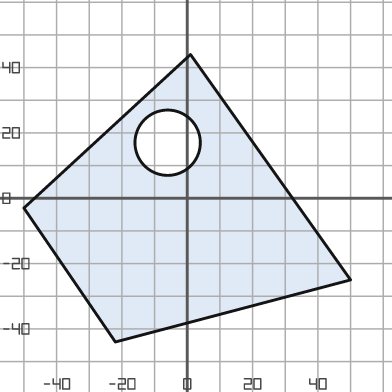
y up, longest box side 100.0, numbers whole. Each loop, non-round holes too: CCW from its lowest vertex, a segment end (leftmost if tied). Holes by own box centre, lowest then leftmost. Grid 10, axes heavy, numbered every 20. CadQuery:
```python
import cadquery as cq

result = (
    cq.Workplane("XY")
    .moveTo(-22.0, -44.0)
    .lineTo(50.0, -25.0)
    .lineTo(1.0, 44.0)
    .lineTo(-50.0, -3.0)
    .close()
    .moveTo(-6.0, 17.0)
    .circle(10.0)
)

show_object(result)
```